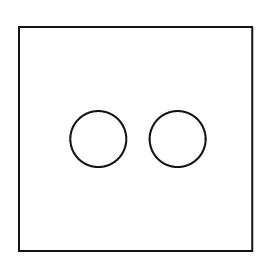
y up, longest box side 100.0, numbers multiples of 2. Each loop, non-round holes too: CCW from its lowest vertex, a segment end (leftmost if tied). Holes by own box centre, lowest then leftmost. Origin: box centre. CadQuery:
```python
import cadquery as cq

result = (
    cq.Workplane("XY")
    .moveTo(-50.0, -48.0)
    .lineTo(50.0, -48.0)
    .lineTo(50.0, 48.0)
    .lineTo(-50.0, 48.0)
    .close()
    .moveTo(-16.0, 0.0)
    .circle(12.0)
    .moveTo(18.0, 0.0)
    .circle(12.0)
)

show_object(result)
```